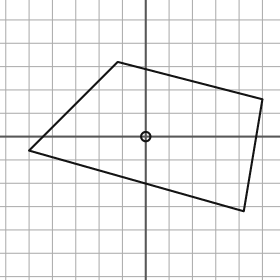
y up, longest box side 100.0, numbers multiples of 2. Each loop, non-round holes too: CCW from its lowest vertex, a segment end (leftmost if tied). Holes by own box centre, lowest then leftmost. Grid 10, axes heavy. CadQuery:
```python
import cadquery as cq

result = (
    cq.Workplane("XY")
    .moveTo(42.0, -32.0)
    .lineTo(50.0, 16.0)
    .lineTo(-12.0, 32.0)
    .lineTo(-50.0, -6.0)
    .close()
    .moveTo(0.0, 0.0)
    .circle(2.0)
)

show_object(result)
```